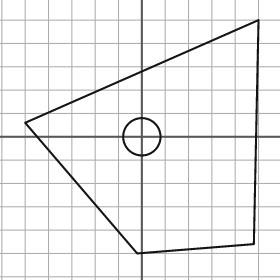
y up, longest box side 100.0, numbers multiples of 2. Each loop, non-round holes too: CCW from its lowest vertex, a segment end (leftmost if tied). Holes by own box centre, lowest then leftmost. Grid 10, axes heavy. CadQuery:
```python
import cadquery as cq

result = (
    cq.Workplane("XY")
    .moveTo(-2.0, -50.0)
    .lineTo(48.0, -46.0)
    .lineTo(50.0, 50.0)
    .lineTo(-50.0, 6.0)
    .close()
    .moveTo(0.0, 0.0)
    .circle(8.0)
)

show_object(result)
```